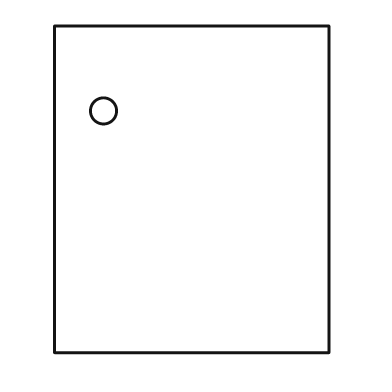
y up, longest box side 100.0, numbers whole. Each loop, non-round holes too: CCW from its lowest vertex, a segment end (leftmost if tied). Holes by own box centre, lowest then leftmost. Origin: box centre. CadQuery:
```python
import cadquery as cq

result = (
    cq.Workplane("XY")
    .moveTo(-42.0, -50.0)
    .lineTo(42.0, -50.0)
    .lineTo(42.0, 50.0)
    .lineTo(-42.0, 50.0)
    .close()
    .moveTo(-27.0, 24.0)
    .circle(4.0)
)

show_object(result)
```